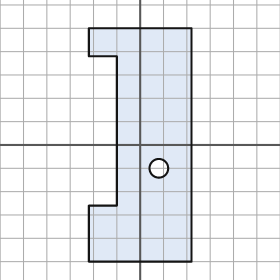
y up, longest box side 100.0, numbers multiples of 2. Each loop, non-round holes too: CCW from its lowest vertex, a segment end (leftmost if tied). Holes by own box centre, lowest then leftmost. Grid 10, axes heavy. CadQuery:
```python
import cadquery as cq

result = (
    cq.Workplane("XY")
    .moveTo(-22.0, -50.0)
    .lineTo(22.0, -50.0)
    .lineTo(22.0, 50.0)
    .lineTo(-22.0, 50.0)
    .lineTo(-22.0, 38.0)
    .lineTo(-10.0, 38.0)
    .lineTo(-10.0, -26.0)
    .lineTo(-22.0, -26.0)
    .close()
    .moveTo(8.0, -10.0)
    .circle(4.0)
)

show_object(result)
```